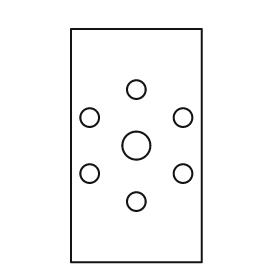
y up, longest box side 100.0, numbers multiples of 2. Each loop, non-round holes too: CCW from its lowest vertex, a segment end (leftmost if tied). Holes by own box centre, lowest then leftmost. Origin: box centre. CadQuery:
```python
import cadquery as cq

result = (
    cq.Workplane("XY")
    .moveTo(-28.0, -50.0)
    .lineTo(28.0, -50.0)
    .lineTo(28.0, 50.0)
    .lineTo(-28.0, 50.0)
    .close()
    .moveTo(0.0, -24.0)
    .circle(4.0)
    .moveTo(-20.0, -12.0)
    .circle(4.0)
    .moveTo(20.0, -12.0)
    .circle(4.0)
    .moveTo(0.0, 0.0)
    .circle(6.0)
    .moveTo(-20.0, 12.0)
    .circle(4.0)
    .moveTo(20.0, 12.0)
    .circle(4.0)
    .moveTo(0.0, 24.0)
    .circle(4.0)
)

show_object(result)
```